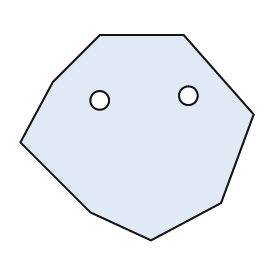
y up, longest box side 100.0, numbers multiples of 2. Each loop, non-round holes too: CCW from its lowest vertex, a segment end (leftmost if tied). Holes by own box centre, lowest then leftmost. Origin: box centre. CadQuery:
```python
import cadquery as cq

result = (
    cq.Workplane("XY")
    .moveTo(6.0, -44.0)
    .lineTo(36.0, -28.0)
    .lineTo(50.0, 10.0)
    .lineTo(20.0, 44.0)
    .lineTo(-16.0, 44.0)
    .lineTo(-36.0, 24.0)
    .lineTo(-50.0, -2.0)
    .lineTo(-20.0, -32.0)
    .close()
    .moveTo(-16.0, 16.0)
    .circle(4.0)
    .moveTo(22.0, 18.0)
    .circle(4.0)
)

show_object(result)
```